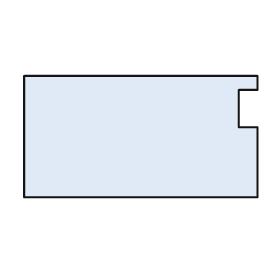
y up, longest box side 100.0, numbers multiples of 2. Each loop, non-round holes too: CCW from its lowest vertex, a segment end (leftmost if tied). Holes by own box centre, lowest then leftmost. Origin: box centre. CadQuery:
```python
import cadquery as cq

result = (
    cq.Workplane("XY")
    .moveTo(-50.0, -26.0)
    .lineTo(50.0, -26.0)
    .lineTo(50.0, 4.0)
    .lineTo(42.0, 4.0)
    .lineTo(42.0, 20.0)
    .lineTo(50.0, 20.0)
    .lineTo(50.0, 26.0)
    .lineTo(-50.0, 26.0)
    .close()
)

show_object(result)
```